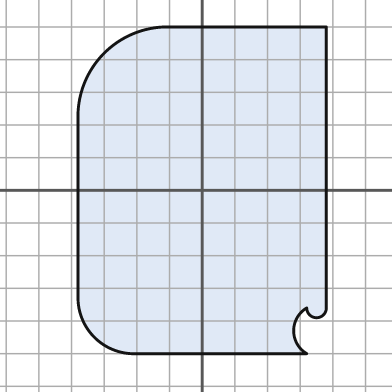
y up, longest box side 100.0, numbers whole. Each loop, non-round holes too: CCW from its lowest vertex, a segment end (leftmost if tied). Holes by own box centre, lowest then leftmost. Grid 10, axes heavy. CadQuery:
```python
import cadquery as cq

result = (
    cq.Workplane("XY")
    .moveTo(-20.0, -50.0)
    .lineTo(32.0, -50.0)
    .threePointArc((28.0, -43.0), (32.0, -36.0))
    .threePointArc((35.0, -39.0), (38.0, -36.0))
    .lineTo(38.0, 50.0)
    .lineTo(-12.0, 50.0)
    .threePointArc((-30.0, 42.0), (-38.0, 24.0))
    .lineTo(-38.0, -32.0)
    .threePointArc((-33.0, -45.0), (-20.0, -50.0))
    .close()
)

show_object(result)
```